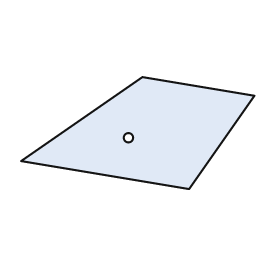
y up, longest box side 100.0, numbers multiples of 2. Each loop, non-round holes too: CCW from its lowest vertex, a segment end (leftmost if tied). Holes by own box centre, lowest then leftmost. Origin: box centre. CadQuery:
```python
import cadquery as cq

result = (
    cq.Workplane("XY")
    .moveTo(22.0, -24.0)
    .lineTo(50.0, 16.0)
    .lineTo(2.0, 24.0)
    .lineTo(-50.0, -12.0)
    .close()
    .moveTo(-4.0, -2.0)
    .circle(2.0)
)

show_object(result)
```